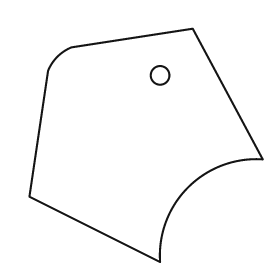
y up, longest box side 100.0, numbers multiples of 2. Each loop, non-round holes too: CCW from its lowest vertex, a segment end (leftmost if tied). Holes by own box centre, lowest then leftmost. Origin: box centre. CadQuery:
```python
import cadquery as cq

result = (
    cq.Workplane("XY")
    .moveTo(6.0, -50.0)
    .threePointArc((18.0, -18.0), (50.0, -6.0))
    .lineTo(20.0, 50.0)
    .lineTo(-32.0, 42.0)
    .threePointArc((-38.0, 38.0), (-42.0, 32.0))
    .lineTo(-50.0, -22.0)
    .close()
    .moveTo(6.0, 30.0)
    .circle(4.0)
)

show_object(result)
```